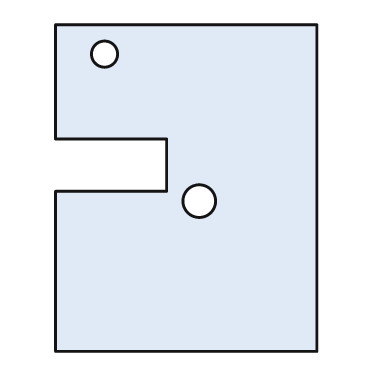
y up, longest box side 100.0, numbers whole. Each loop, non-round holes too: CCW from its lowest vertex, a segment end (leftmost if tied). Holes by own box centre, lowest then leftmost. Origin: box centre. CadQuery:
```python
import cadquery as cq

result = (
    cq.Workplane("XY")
    .moveTo(-40.0, -50.0)
    .lineTo(40.0, -50.0)
    .lineTo(40.0, 50.0)
    .lineTo(-40.0, 50.0)
    .lineTo(-40.0, 15.0)
    .lineTo(-6.0, 15.0)
    .lineTo(-6.0, -1.0)
    .lineTo(-40.0, -1.0)
    .close()
    .moveTo(4.0, -4.0)
    .circle(5.0)
    .moveTo(-25.0, 41.0)
    .circle(4.0)
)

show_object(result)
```